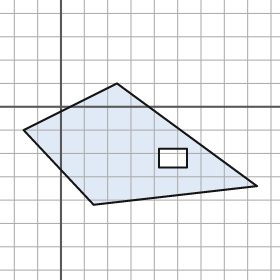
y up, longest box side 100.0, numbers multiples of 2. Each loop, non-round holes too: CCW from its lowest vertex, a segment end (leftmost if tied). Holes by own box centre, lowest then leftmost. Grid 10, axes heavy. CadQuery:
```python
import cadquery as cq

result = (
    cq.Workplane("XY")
    .moveTo(14.0, -42.0)
    .lineTo(84.0, -34.0)
    .lineTo(24.0, 10.0)
    .lineTo(-16.0, -10.0)
    .close()
    .moveTo(42.0, -26.0)
    .lineTo(54.0, -26.0)
    .lineTo(54.0, -18.0)
    .lineTo(42.0, -18.0)
    .close()
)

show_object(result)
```